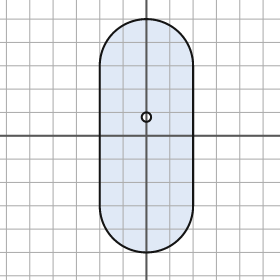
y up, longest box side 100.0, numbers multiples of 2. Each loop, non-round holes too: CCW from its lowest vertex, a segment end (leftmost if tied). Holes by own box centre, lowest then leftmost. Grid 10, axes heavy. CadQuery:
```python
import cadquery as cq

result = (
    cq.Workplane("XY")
    .moveTo(-20.0, -30.0)
    .threePointArc((0.0, -50.0), (20.0, -30.0))
    .lineTo(20.0, 30.0)
    .threePointArc((0.0, 50.0), (-20.0, 30.0))
    .close()
    .moveTo(0.0, 8.0)
    .circle(2.0)
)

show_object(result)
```